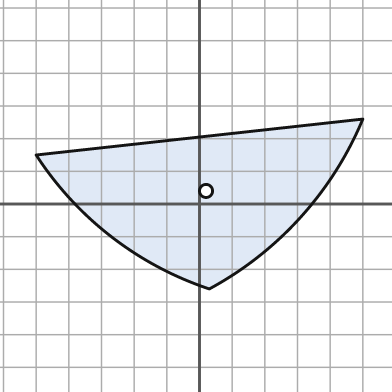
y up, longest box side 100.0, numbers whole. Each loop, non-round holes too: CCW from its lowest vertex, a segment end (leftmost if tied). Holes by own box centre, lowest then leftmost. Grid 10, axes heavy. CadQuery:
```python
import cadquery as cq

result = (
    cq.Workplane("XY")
    .moveTo(3.0, -26.0)
    .threePointArc((31.0, -4.0), (50.0, 26.0))
    .lineTo(-50.0, 15.0)
    .threePointArc((-27.0, -10.0), (3.0, -26.0))
    .close()
    .moveTo(2.0, 4.0)
    .circle(2.0)
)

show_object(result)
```